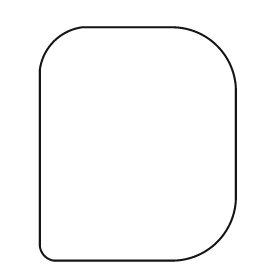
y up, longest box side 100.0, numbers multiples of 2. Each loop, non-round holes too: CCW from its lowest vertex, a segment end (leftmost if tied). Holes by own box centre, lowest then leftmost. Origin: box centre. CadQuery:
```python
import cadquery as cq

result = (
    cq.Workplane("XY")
    .moveTo(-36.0, -50.0)
    .lineTo(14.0, -50.0)
    .threePointArc((34.0, -42.0), (42.0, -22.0))
    .lineTo(42.0, 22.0)
    .threePointArc((34.0, 42.0), (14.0, 50.0))
    .lineTo(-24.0, 50.0)
    .threePointArc((-36.0, 44.0), (-42.0, 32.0))
    .lineTo(-42.0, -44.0)
    .threePointArc((-40.0, -48.0), (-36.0, -50.0))
    .close()
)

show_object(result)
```